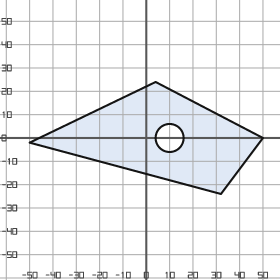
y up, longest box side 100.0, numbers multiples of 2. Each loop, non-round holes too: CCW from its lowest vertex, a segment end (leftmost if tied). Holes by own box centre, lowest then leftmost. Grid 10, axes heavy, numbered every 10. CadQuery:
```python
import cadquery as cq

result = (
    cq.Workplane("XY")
    .moveTo(32.0, -24.0)
    .lineTo(50.0, 0.0)
    .lineTo(4.0, 24.0)
    .lineTo(-50.0, -2.0)
    .close()
    .moveTo(10.0, 0.0)
    .circle(6.0)
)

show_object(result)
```